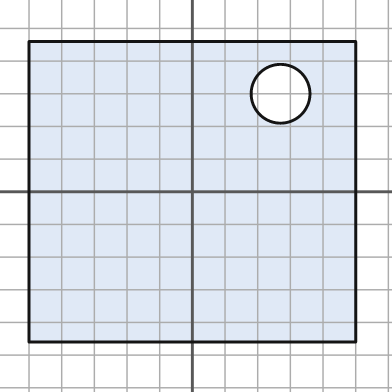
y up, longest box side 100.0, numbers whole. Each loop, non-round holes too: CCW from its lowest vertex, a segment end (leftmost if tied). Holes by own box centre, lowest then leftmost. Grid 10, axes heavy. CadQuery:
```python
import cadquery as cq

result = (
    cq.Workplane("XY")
    .moveTo(-50.0, -46.0)
    .lineTo(50.0, -46.0)
    .lineTo(50.0, 46.0)
    .lineTo(-50.0, 46.0)
    .close()
    .moveTo(27.0, 30.0)
    .circle(9.0)
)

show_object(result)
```